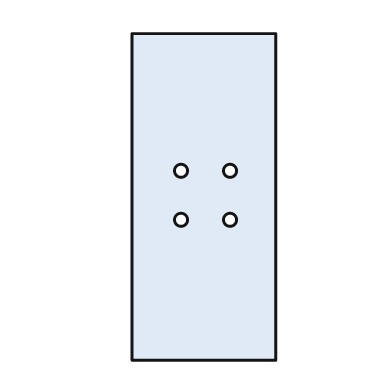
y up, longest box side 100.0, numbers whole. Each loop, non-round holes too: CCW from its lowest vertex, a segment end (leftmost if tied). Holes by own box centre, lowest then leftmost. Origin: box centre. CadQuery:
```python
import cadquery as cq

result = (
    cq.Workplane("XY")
    .moveTo(-22.0, -50.0)
    .lineTo(22.0, -50.0)
    .lineTo(22.0, 50.0)
    .lineTo(-22.0, 50.0)
    .close()
    .moveTo(-7.0, -7.0)
    .circle(2.0)
    .moveTo(8.0, -7.0)
    .circle(2.0)
    .moveTo(-7.0, 8.0)
    .circle(2.0)
    .moveTo(8.0, 8.0)
    .circle(2.0)
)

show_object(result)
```